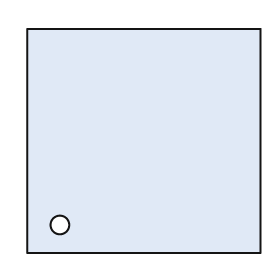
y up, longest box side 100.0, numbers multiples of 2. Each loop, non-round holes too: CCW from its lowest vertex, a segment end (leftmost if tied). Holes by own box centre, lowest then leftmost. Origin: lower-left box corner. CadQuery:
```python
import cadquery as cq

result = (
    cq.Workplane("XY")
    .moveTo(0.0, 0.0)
    .lineTo(100.0, 0.0)
    .lineTo(100.0, 96.0)
    .lineTo(0.0, 96.0)
    .close()
    .moveTo(14.0, 12.0)
    .circle(4.0)
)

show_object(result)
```